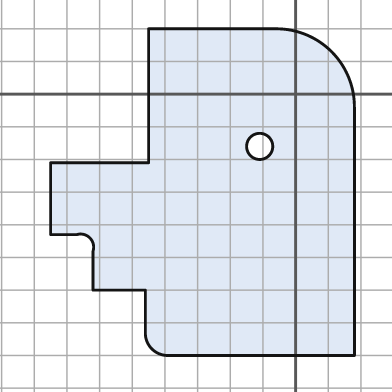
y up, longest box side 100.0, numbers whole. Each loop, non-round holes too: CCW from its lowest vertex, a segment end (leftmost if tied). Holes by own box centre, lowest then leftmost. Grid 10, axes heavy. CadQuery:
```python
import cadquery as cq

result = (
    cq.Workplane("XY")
    .moveTo(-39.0, -80.0)
    .lineTo(18.0, -80.0)
    .lineTo(18.0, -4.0)
    .threePointArc((11.0, 13.0), (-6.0, 20.0))
    .lineTo(-45.0, 20.0)
    .lineTo(-45.0, -21.0)
    .lineTo(-75.0, -21.0)
    .lineTo(-75.0, -43.0)
    .lineTo(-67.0, -43.0)
    .threePointArc((-63.0, -44.0), (-62.0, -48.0))
    .lineTo(-62.0, -60.0)
    .lineTo(-46.0, -60.0)
    .lineTo(-46.0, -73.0)
    .threePointArc((-44.0, -78.0), (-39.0, -80.0))
    .close()
    .moveTo(-11.0, -16.0)
    .circle(4.0)
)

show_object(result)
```